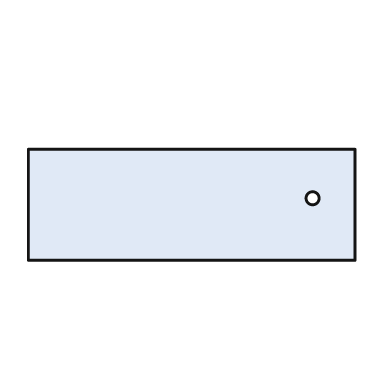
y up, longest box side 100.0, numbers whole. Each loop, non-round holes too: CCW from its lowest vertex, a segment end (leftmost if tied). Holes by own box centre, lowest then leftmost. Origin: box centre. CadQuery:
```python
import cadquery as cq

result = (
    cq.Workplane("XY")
    .moveTo(-50.0, -17.0)
    .lineTo(50.0, -17.0)
    .lineTo(50.0, 17.0)
    .lineTo(-50.0, 17.0)
    .close()
    .moveTo(37.0, 2.0)
    .circle(2.0)
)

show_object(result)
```